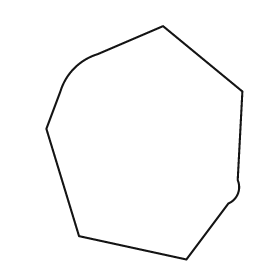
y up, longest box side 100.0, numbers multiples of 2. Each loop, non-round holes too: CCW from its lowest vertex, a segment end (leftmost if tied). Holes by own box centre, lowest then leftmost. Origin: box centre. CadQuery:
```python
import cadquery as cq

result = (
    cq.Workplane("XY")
    .moveTo(18.0, -50.0)
    .lineTo(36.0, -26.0)
    .threePointArc((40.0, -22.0), (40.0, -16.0))
    .lineTo(42.0, 22.0)
    .lineTo(8.0, 50.0)
    .lineTo(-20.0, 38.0)
    .threePointArc((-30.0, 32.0), (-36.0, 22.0))
    .lineTo(-42.0, 6.0)
    .lineTo(-28.0, -40.0)
    .close()
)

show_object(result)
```